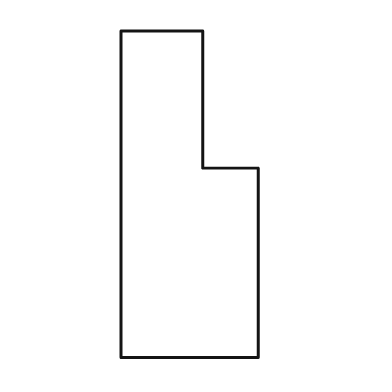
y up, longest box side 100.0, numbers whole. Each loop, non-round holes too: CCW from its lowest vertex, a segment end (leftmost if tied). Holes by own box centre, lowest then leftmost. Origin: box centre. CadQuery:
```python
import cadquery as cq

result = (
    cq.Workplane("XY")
    .moveTo(-21.0, -50.0)
    .lineTo(21.0, -50.0)
    .lineTo(21.0, 8.0)
    .lineTo(4.0, 8.0)
    .lineTo(4.0, 50.0)
    .lineTo(-21.0, 50.0)
    .close()
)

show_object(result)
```